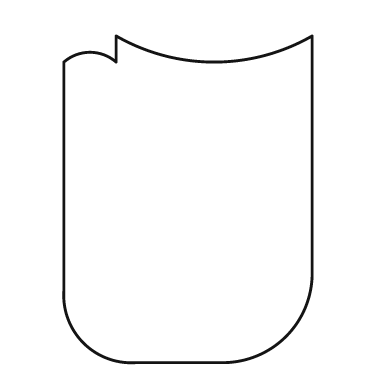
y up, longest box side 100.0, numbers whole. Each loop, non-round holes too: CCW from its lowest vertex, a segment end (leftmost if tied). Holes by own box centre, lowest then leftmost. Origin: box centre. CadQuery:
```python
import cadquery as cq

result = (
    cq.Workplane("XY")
    .moveTo(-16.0, -50.0)
    .lineTo(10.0, -50.0)
    .threePointArc((30.0, -42.0), (38.0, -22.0))
    .lineTo(38.0, 50.0)
    .threePointArc((8.0, 42.0), (-22.0, 50.0))
    .lineTo(-22.0, 42.0)
    .threePointArc((-30.0, 45.0), (-38.0, 42.0))
    .lineTo(-38.0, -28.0)
    .threePointArc((-32.0, -44.0), (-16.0, -50.0))
    .close()
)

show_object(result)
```